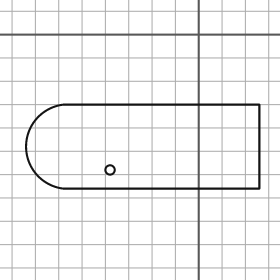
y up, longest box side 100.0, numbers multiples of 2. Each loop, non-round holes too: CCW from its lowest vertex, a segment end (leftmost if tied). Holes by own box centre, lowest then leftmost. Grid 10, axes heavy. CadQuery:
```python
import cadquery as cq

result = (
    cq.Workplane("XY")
    .moveTo(-58.0, -66.0)
    .lineTo(26.0, -66.0)
    .lineTo(26.0, -30.0)
    .lineTo(-58.0, -30.0)
    .threePointArc((-74.0, -48.0), (-58.0, -66.0))
    .close()
    .moveTo(-38.0, -58.0)
    .circle(2.0)
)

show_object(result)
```